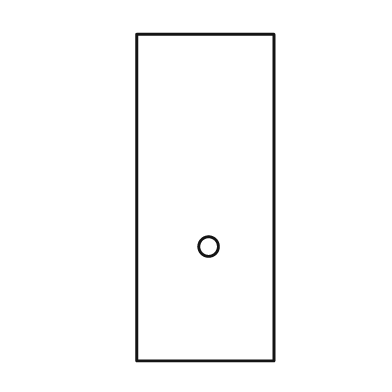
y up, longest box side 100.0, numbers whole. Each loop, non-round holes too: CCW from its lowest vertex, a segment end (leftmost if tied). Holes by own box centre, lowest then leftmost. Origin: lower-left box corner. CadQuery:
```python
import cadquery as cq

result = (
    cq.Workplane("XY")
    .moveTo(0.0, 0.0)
    .lineTo(42.0, 0.0)
    .lineTo(42.0, 100.0)
    .lineTo(0.0, 100.0)
    .close()
    .moveTo(22.0, 35.0)
    .circle(3.0)
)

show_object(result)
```